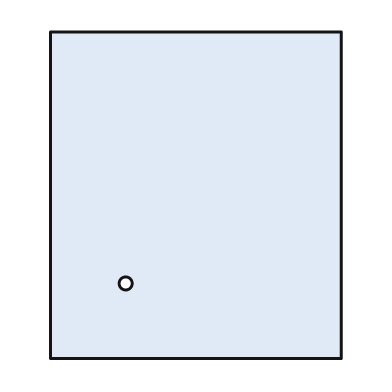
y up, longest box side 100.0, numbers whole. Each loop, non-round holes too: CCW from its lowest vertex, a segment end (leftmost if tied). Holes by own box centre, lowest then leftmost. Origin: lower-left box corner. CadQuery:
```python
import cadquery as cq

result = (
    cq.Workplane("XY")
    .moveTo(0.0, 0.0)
    .lineTo(89.0, 0.0)
    .lineTo(89.0, 100.0)
    .lineTo(0.0, 100.0)
    .close()
    .moveTo(23.0, 23.0)
    .circle(2.0)
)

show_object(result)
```